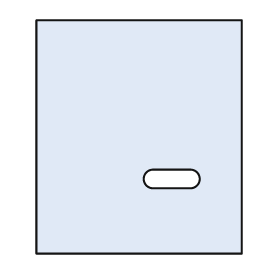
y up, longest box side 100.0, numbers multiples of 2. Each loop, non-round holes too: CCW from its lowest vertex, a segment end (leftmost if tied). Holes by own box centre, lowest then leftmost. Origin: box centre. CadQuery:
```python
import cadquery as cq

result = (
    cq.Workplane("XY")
    .moveTo(-44.0, -50.0)
    .lineTo(44.0, -50.0)
    .lineTo(44.0, 50.0)
    .lineTo(-44.0, 50.0)
    .close()
    .moveTo(6.0, -22.0)
    .lineTo(22.0, -22.0)
    .threePointArc((26.0, -18.0), (22.0, -14.0))
    .lineTo(6.0, -14.0)
    .threePointArc((2.0, -18.0), (6.0, -22.0))
    .close()
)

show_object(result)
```